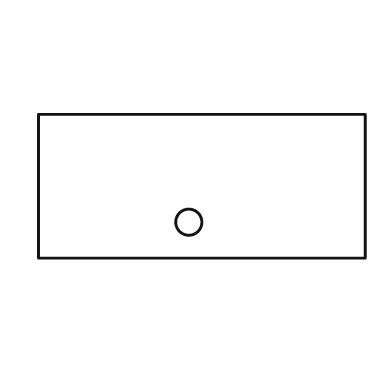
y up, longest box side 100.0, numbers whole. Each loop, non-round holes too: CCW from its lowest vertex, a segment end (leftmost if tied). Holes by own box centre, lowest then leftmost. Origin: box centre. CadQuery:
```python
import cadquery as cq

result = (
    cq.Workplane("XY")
    .moveTo(-50.0, -22.0)
    .lineTo(50.0, -22.0)
    .lineTo(50.0, 22.0)
    .lineTo(-50.0, 22.0)
    .close()
    .moveTo(-4.0, -11.0)
    .circle(4.0)
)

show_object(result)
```